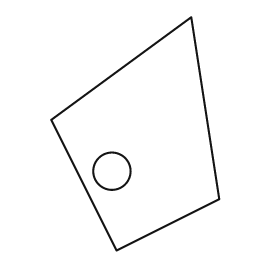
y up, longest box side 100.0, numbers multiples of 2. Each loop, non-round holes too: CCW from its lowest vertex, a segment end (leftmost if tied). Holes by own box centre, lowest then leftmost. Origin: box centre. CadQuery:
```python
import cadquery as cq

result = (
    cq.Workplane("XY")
    .moveTo(-8.0, -50.0)
    .lineTo(36.0, -28.0)
    .lineTo(24.0, 50.0)
    .lineTo(-36.0, 6.0)
    .close()
    .moveTo(-10.0, -16.0)
    .circle(8.0)
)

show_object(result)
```